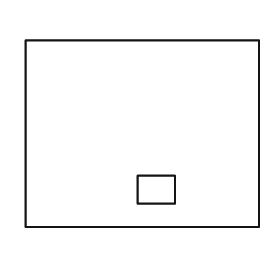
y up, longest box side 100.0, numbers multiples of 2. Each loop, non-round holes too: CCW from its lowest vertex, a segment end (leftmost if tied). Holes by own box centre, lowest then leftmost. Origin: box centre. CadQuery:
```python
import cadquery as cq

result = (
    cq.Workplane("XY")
    .moveTo(-50.0, -40.0)
    .lineTo(50.0, -40.0)
    .lineTo(50.0, 40.0)
    .lineTo(-50.0, 40.0)
    .close()
    .moveTo(-2.0, -30.0)
    .lineTo(14.0, -30.0)
    .lineTo(14.0, -18.0)
    .lineTo(-2.0, -18.0)
    .close()
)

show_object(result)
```